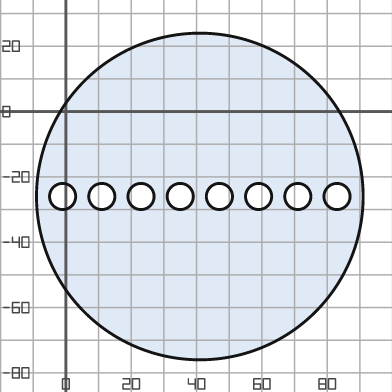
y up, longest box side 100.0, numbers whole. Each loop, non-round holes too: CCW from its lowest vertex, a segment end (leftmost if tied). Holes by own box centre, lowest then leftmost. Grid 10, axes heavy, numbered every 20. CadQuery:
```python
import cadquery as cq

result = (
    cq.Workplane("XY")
    .moveTo(41.0, -26.0)
    .circle(50.0)
    .moveTo(-1.0, -26.0)
    .circle(4.0)
    .moveTo(11.0, -26.0)
    .circle(4.0)
    .moveTo(23.0, -26.0)
    .circle(4.0)
    .moveTo(35.0, -26.0)
    .circle(4.0)
    .moveTo(47.0, -26.0)
    .circle(4.0)
    .moveTo(59.0, -26.0)
    .circle(4.0)
    .moveTo(71.0, -26.0)
    .circle(4.0)
    .moveTo(83.0, -26.0)
    .circle(4.0)
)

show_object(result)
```